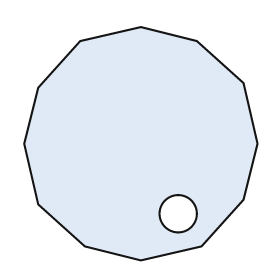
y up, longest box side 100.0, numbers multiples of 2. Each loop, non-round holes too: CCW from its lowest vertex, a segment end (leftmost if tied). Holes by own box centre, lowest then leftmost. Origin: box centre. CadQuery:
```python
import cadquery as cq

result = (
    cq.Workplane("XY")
    .moveTo(0.0, -50.0)
    .lineTo(26.0, -44.0)
    .lineTo(44.0, -24.0)
    .lineTo(50.0, 0.0)
    .lineTo(44.0, 26.0)
    .lineTo(24.0, 44.0)
    .lineTo(0.0, 50.0)
    .lineTo(-26.0, 44.0)
    .lineTo(-44.0, 24.0)
    .lineTo(-50.0, 0.0)
    .lineTo(-44.0, -26.0)
    .lineTo(-24.0, -44.0)
    .close()
    .moveTo(16.0, -30.0)
    .circle(8.0)
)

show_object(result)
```